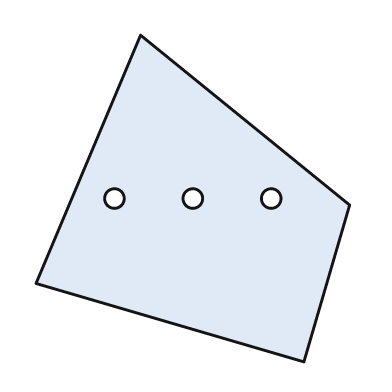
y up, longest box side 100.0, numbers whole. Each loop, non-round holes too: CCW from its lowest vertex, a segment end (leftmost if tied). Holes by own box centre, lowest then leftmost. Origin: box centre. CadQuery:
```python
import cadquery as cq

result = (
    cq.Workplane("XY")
    .moveTo(34.0, -50.0)
    .lineTo(48.0, -2.0)
    .lineTo(-16.0, 50.0)
    .lineTo(-48.0, -26.0)
    .close()
    .moveTo(-24.0, 0.0)
    .circle(3.0)
    .moveTo(0.0, 0.0)
    .circle(3.0)
    .moveTo(24.0, 0.0)
    .circle(3.0)
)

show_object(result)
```